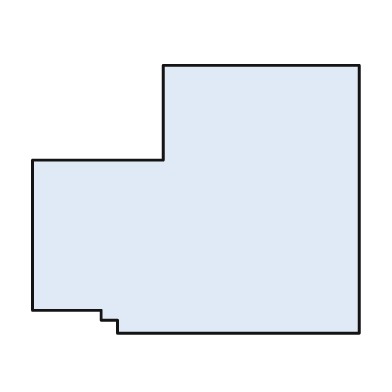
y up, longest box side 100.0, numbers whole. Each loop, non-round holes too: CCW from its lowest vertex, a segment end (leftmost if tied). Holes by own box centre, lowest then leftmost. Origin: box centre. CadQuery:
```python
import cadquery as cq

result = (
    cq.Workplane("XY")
    .moveTo(-24.0, -41.0)
    .lineTo(50.0, -41.0)
    .lineTo(50.0, 41.0)
    .lineTo(-10.0, 41.0)
    .lineTo(-10.0, 12.0)
    .lineTo(-50.0, 12.0)
    .lineTo(-50.0, -34.0)
    .lineTo(-29.0, -34.0)
    .lineTo(-29.0, -37.0)
    .lineTo(-24.0, -37.0)
    .close()
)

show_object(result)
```